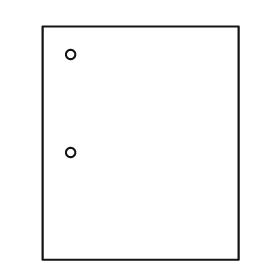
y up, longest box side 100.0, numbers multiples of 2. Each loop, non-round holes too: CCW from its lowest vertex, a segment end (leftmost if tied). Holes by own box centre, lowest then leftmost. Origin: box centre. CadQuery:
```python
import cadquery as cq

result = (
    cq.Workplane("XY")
    .moveTo(-42.0, -50.0)
    .lineTo(42.0, -50.0)
    .lineTo(42.0, 50.0)
    .lineTo(-42.0, 50.0)
    .close()
    .moveTo(-30.0, -4.0)
    .circle(2.0)
    .moveTo(-30.0, 38.0)
    .circle(2.0)
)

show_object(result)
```